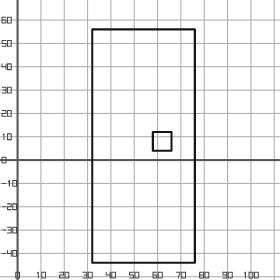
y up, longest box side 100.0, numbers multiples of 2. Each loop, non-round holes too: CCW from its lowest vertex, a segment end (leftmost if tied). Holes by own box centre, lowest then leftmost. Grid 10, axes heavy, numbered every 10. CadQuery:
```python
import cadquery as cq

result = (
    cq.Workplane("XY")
    .moveTo(32.0, -44.0)
    .lineTo(76.0, -44.0)
    .lineTo(76.0, 56.0)
    .lineTo(32.0, 56.0)
    .close()
    .moveTo(58.0, 4.0)
    .lineTo(66.0, 4.0)
    .lineTo(66.0, 12.0)
    .lineTo(58.0, 12.0)
    .close()
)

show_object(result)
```